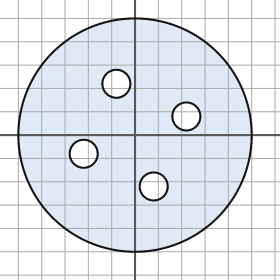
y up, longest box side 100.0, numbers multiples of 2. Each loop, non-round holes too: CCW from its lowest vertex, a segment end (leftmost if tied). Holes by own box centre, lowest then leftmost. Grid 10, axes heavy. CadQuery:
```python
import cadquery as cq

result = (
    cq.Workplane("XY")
    .moveTo(0.0, 0.0)
    .circle(50.0)
    .moveTo(8.0, -22.0)
    .circle(6.0)
    .moveTo(-22.0, -8.0)
    .circle(6.0)
    .moveTo(22.0, 8.0)
    .circle(6.0)
    .moveTo(-8.0, 22.0)
    .circle(6.0)
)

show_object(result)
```